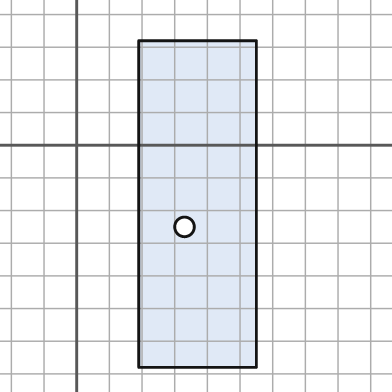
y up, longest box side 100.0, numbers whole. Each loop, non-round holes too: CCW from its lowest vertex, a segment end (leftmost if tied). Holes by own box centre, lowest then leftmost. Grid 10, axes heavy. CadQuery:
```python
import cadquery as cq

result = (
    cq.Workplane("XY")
    .moveTo(19.0, -68.0)
    .lineTo(55.0, -68.0)
    .lineTo(55.0, 32.0)
    .lineTo(19.0, 32.0)
    .close()
    .moveTo(33.0, -25.0)
    .circle(3.0)
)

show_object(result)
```